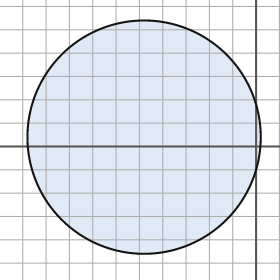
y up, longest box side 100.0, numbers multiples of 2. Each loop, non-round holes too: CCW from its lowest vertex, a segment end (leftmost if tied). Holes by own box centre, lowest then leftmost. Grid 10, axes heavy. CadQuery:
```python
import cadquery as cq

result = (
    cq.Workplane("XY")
    .moveTo(-48.0, 4.0)
    .circle(50.0)
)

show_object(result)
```